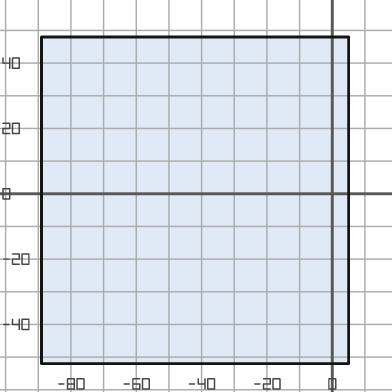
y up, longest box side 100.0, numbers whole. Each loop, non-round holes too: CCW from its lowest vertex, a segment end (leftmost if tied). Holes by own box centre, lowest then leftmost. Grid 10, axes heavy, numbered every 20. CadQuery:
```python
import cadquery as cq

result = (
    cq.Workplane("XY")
    .moveTo(-89.0, -52.0)
    .lineTo(5.0, -52.0)
    .lineTo(5.0, 48.0)
    .lineTo(-89.0, 48.0)
    .close()
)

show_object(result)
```